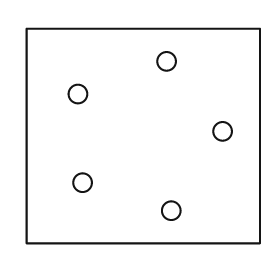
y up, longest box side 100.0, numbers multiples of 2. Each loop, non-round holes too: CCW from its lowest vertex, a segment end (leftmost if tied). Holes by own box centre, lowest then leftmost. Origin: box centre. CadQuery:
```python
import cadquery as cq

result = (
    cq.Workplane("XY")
    .moveTo(-50.0, -46.0)
    .lineTo(50.0, -46.0)
    .lineTo(50.0, 46.0)
    .lineTo(-50.0, 46.0)
    .close()
    .moveTo(12.0, -32.0)
    .circle(4.0)
    .moveTo(-26.0, -20.0)
    .circle(4.0)
    .moveTo(34.0, 2.0)
    .circle(4.0)
    .moveTo(-28.0, 18.0)
    .circle(4.0)
    .moveTo(10.0, 32.0)
    .circle(4.0)
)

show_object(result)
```